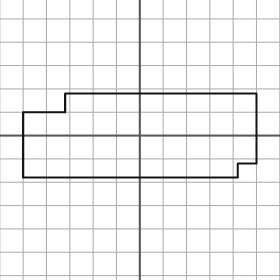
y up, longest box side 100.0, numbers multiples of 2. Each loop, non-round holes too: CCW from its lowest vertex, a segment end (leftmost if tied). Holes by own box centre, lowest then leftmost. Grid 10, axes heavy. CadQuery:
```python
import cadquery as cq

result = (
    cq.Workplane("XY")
    .moveTo(-50.0, -18.0)
    .lineTo(42.0, -18.0)
    .lineTo(42.0, -12.0)
    .lineTo(50.0, -12.0)
    .lineTo(50.0, 18.0)
    .lineTo(-32.0, 18.0)
    .lineTo(-32.0, 10.0)
    .lineTo(-50.0, 10.0)
    .close()
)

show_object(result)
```